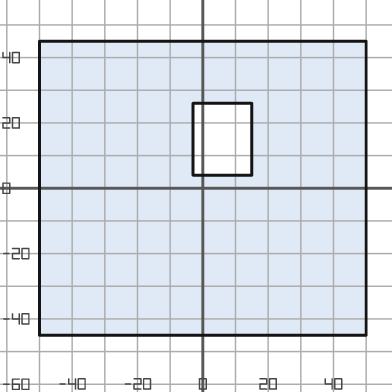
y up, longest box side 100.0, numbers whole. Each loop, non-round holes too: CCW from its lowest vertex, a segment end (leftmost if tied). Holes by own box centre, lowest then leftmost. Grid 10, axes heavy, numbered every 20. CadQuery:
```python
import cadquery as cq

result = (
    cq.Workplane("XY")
    .moveTo(-50.0, -45.0)
    .lineTo(50.0, -45.0)
    .lineTo(50.0, 45.0)
    .lineTo(-50.0, 45.0)
    .close()
    .moveTo(-3.0, 4.0)
    .lineTo(15.0, 4.0)
    .lineTo(15.0, 26.0)
    .lineTo(-3.0, 26.0)
    .close()
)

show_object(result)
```